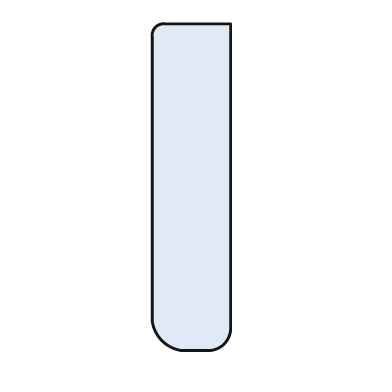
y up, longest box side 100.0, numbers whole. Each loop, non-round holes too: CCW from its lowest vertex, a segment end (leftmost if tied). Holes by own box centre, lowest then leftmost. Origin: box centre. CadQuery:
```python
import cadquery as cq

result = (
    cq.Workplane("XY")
    .moveTo(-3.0, -50.0)
    .lineTo(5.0, -50.0)
    .threePointArc((10.0, -48.0), (12.0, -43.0))
    .lineTo(12.0, 50.0)
    .lineTo(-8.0, 50.0)
    .threePointArc((-11.0, 49.0), (-12.0, 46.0))
    .lineTo(-12.0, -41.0)
    .threePointArc((-9.0, -47.0), (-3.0, -50.0))
    .close()
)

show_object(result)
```